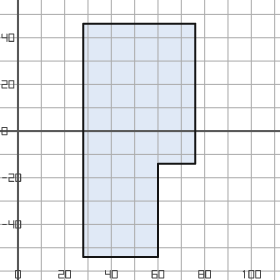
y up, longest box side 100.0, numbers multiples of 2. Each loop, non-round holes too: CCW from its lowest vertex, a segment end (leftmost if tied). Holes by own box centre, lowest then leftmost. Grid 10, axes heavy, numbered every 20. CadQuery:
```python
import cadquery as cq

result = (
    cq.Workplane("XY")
    .moveTo(28.0, -54.0)
    .lineTo(60.0, -54.0)
    .lineTo(60.0, -14.0)
    .lineTo(76.0, -14.0)
    .lineTo(76.0, 46.0)
    .lineTo(28.0, 46.0)
    .close()
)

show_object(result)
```